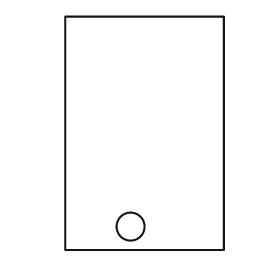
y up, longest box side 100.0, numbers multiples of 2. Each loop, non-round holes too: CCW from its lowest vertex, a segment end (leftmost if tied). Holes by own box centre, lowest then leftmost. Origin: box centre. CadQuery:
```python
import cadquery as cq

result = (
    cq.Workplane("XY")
    .moveTo(-34.0, -50.0)
    .lineTo(34.0, -50.0)
    .lineTo(34.0, 50.0)
    .lineTo(-34.0, 50.0)
    .close()
    .moveTo(-6.0, -40.0)
    .circle(6.0)
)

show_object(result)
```